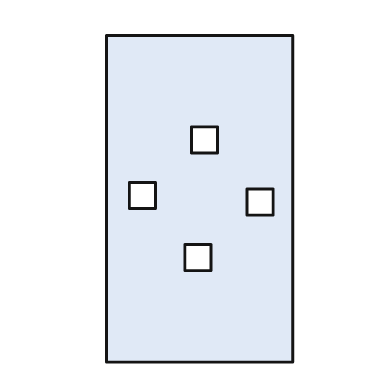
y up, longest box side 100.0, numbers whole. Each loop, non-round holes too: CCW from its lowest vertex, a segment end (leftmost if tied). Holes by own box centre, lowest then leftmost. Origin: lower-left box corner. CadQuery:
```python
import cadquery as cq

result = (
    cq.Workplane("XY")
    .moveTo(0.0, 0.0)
    .lineTo(57.0, 0.0)
    .lineTo(57.0, 100.0)
    .lineTo(0.0, 100.0)
    .close()
    .moveTo(24.0, 28.0)
    .lineTo(32.0, 28.0)
    .lineTo(32.0, 36.0)
    .lineTo(24.0, 36.0)
    .close()
    .moveTo(43.0, 45.0)
    .lineTo(51.0, 45.0)
    .lineTo(51.0, 53.0)
    .lineTo(43.0, 53.0)
    .close()
    .moveTo(7.0, 47.0)
    .lineTo(15.0, 47.0)
    .lineTo(15.0, 55.0)
    .lineTo(7.0, 55.0)
    .close()
    .moveTo(26.0, 64.0)
    .lineTo(34.0, 64.0)
    .lineTo(34.0, 72.0)
    .lineTo(26.0, 72.0)
    .close()
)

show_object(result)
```